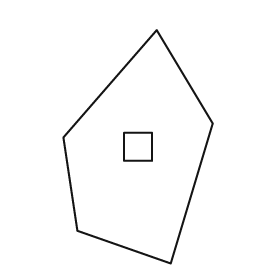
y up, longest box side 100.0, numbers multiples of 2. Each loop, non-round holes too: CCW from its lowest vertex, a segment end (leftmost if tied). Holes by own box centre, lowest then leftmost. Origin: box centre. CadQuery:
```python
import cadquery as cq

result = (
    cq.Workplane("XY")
    .moveTo(14.0, -50.0)
    .lineTo(32.0, 10.0)
    .lineTo(8.0, 50.0)
    .lineTo(-32.0, 4.0)
    .lineTo(-26.0, -36.0)
    .close()
    .moveTo(-6.0, -6.0)
    .lineTo(6.0, -6.0)
    .lineTo(6.0, 6.0)
    .lineTo(-6.0, 6.0)
    .close()
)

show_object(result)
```